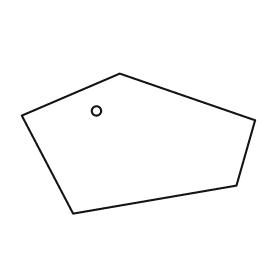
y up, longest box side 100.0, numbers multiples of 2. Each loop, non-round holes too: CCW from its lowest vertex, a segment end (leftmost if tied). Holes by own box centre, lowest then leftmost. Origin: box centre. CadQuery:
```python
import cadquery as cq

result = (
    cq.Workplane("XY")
    .moveTo(-28.0, -30.0)
    .lineTo(42.0, -18.0)
    .lineTo(50.0, 10.0)
    .lineTo(-8.0, 30.0)
    .lineTo(-50.0, 12.0)
    .close()
    .moveTo(-18.0, 14.0)
    .circle(2.0)
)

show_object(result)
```